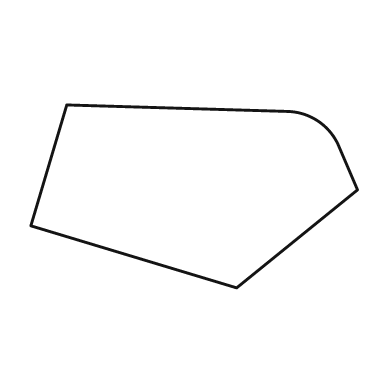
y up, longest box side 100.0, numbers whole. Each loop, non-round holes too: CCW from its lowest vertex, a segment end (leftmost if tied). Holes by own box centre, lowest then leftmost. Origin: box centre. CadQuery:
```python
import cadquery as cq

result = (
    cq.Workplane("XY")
    .moveTo(13.0, -28.0)
    .lineTo(50.0, 2.0)
    .lineTo(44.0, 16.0)
    .threePointArc((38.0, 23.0), (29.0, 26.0))
    .lineTo(-39.0, 28.0)
    .lineTo(-50.0, -9.0)
    .close()
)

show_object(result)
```